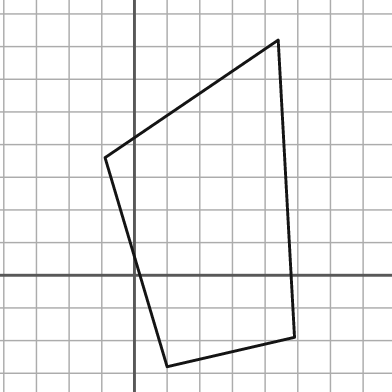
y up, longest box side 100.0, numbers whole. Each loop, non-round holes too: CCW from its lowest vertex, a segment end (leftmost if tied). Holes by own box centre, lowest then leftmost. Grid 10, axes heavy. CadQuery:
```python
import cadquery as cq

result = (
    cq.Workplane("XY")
    .moveTo(10.0, -28.0)
    .lineTo(49.0, -19.0)
    .lineTo(44.0, 72.0)
    .lineTo(-9.0, 36.0)
    .close()
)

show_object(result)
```